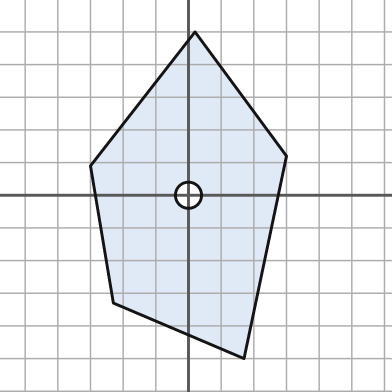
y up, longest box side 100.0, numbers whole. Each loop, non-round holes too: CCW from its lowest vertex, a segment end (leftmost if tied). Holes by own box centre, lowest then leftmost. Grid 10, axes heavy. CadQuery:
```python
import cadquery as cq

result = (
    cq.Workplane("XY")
    .moveTo(17.0, -50.0)
    .lineTo(30.0, 12.0)
    .lineTo(2.0, 50.0)
    .lineTo(-30.0, 9.0)
    .lineTo(-23.0, -33.0)
    .close()
    .moveTo(0.0, 0.0)
    .circle(4.0)
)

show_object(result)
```